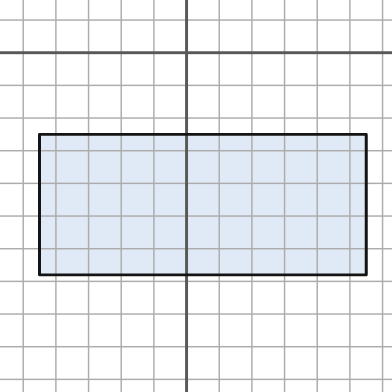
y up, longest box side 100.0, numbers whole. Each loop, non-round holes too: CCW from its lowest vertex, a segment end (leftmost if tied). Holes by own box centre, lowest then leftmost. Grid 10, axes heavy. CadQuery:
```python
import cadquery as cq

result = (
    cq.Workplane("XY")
    .moveTo(-45.0, -68.0)
    .lineTo(55.0, -68.0)
    .lineTo(55.0, -25.0)
    .lineTo(-45.0, -25.0)
    .close()
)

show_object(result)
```